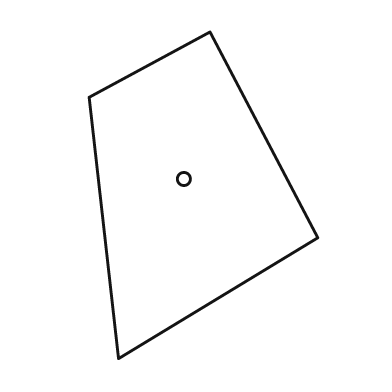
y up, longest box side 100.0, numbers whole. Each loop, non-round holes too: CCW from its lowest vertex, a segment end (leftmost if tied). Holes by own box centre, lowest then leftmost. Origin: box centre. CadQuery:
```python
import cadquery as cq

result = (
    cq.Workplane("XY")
    .moveTo(-26.0, -50.0)
    .lineTo(35.0, -13.0)
    .lineTo(2.0, 50.0)
    .lineTo(-35.0, 30.0)
    .close()
    .moveTo(-6.0, 5.0)
    .circle(2.0)
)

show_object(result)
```